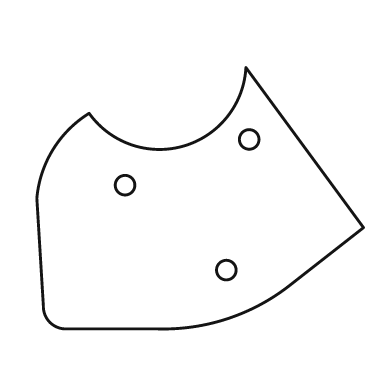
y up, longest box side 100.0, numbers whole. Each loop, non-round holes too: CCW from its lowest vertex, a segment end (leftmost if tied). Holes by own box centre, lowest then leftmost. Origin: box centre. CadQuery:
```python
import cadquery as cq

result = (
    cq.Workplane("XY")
    .moveTo(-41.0, -40.0)
    .lineTo(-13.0, -40.0)
    .threePointArc((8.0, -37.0), (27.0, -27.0))
    .lineTo(50.0, -9.0)
    .lineTo(14.0, 40.0)
    .threePointArc((-5.0, 16.0), (-34.0, 26.0))
    .threePointArc((-45.0, 15.0), (-50.0, 0.0))
    .lineTo(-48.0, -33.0)
    .threePointArc((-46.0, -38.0), (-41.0, -40.0))
    .close()
    .moveTo(8.0, -22.0)
    .circle(3.0)
    .moveTo(-23.0, 4.0)
    .circle(3.0)
    .moveTo(15.0, 18.0)
    .circle(3.0)
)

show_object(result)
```